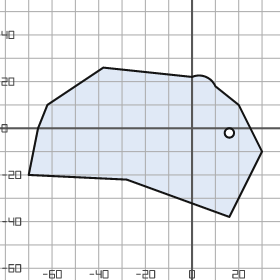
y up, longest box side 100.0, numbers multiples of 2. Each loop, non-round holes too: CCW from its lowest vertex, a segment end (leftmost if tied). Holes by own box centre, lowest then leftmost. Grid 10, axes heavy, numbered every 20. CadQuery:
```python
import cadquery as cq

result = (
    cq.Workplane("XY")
    .moveTo(16.0, -38.0)
    .lineTo(30.0, -10.0)
    .lineTo(20.0, 10.0)
    .lineTo(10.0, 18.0)
    .threePointArc((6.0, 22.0), (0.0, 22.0))
    .lineTo(-38.0, 26.0)
    .lineTo(-62.0, 10.0)
    .lineTo(-66.0, 0.0)
    .lineTo(-70.0, -20.0)
    .lineTo(-28.0, -22.0)
    .close()
    .moveTo(16.0, -2.0)
    .circle(2.0)
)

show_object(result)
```